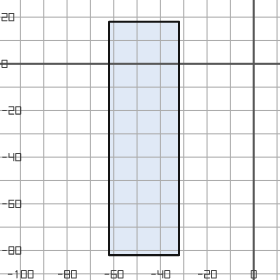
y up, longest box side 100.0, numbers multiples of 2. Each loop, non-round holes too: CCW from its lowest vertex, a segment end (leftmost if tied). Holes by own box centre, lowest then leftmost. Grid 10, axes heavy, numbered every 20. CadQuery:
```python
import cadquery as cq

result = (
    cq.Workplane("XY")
    .moveTo(-62.0, -82.0)
    .lineTo(-32.0, -82.0)
    .lineTo(-32.0, 18.0)
    .lineTo(-62.0, 18.0)
    .close()
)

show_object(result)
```